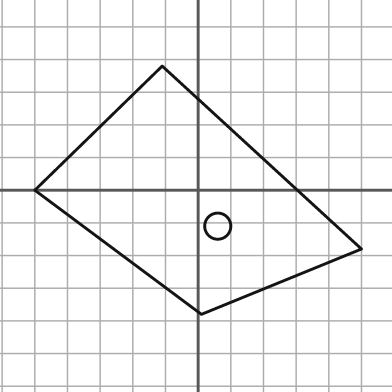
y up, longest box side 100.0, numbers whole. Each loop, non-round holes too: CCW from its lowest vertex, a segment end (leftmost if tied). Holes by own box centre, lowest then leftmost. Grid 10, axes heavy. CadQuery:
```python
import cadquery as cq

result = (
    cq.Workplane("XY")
    .moveTo(1.0, -38.0)
    .lineTo(50.0, -18.0)
    .lineTo(-11.0, 38.0)
    .lineTo(-50.0, 0.0)
    .close()
    .moveTo(6.0, -11.0)
    .circle(4.0)
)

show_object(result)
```